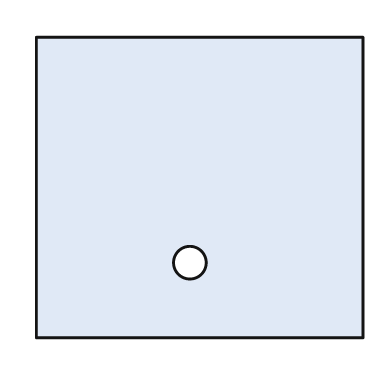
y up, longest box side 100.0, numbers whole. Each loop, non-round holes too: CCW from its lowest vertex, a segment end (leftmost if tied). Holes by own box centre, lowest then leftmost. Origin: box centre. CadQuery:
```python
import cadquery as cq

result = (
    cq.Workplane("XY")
    .moveTo(-50.0, -46.0)
    .lineTo(50.0, -46.0)
    .lineTo(50.0, 46.0)
    .lineTo(-50.0, 46.0)
    .close()
    .moveTo(-3.0, -23.0)
    .circle(5.0)
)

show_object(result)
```